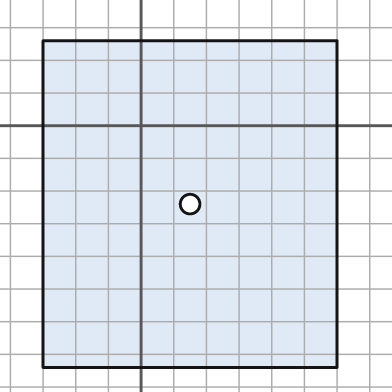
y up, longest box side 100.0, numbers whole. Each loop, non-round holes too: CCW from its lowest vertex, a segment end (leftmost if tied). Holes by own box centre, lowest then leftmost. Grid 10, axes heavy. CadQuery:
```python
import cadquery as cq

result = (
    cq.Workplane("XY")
    .moveTo(-30.0, -74.0)
    .lineTo(60.0, -74.0)
    .lineTo(60.0, 26.0)
    .lineTo(-30.0, 26.0)
    .close()
    .moveTo(15.0, -24.0)
    .circle(3.0)
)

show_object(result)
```